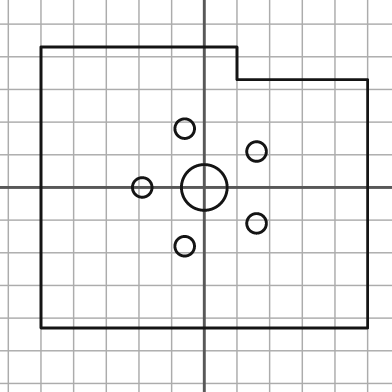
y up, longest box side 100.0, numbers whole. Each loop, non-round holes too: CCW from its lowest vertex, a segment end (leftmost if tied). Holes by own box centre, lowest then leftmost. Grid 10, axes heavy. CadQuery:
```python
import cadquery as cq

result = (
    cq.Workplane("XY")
    .moveTo(-50.0, -43.0)
    .lineTo(50.0, -43.0)
    .lineTo(50.0, 33.0)
    .lineTo(10.0, 33.0)
    .lineTo(10.0, 43.0)
    .lineTo(-50.0, 43.0)
    .close()
    .moveTo(-6.0, -18.0)
    .circle(3.0)
    .moveTo(16.0, -11.0)
    .circle(3.0)
    .moveTo(-19.0, 0.0)
    .circle(3.0)
    .moveTo(0.0, 0.0)
    .circle(7.0)
    .moveTo(16.0, 11.0)
    .circle(3.0)
    .moveTo(-6.0, 18.0)
    .circle(3.0)
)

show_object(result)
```